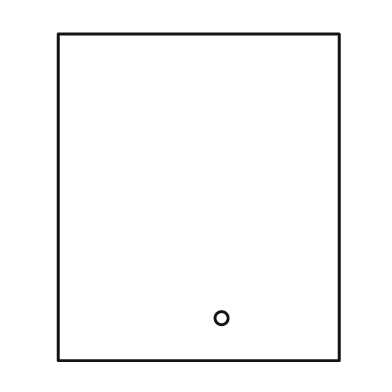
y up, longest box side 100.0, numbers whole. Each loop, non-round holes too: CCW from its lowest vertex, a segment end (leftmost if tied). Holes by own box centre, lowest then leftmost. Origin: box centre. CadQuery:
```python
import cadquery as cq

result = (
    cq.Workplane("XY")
    .moveTo(-43.0, -50.0)
    .lineTo(43.0, -50.0)
    .lineTo(43.0, 50.0)
    .lineTo(-43.0, 50.0)
    .close()
    .moveTo(7.0, -37.0)
    .circle(2.0)
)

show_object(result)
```